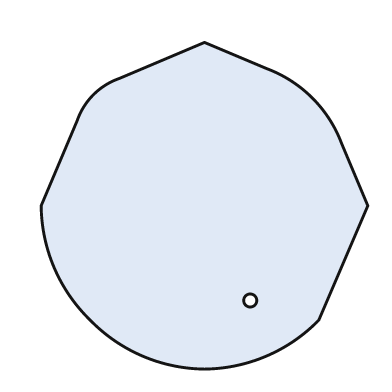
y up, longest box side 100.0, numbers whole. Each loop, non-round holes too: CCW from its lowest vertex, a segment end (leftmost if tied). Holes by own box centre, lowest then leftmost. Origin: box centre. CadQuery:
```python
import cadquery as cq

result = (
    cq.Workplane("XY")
    .moveTo(0.0, -50.0)
    .threePointArc((19.0, -46.0), (35.0, -35.0))
    .lineTo(50.0, 0.0)
    .lineTo(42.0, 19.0)
    .threePointArc((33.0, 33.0), (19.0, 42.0))
    .lineTo(0.0, 50.0)
    .lineTo(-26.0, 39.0)
    .threePointArc((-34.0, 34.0), (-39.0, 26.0))
    .lineTo(-50.0, 0.0)
    .threePointArc((-46.0, -19.0), (-35.0, -35.0))
    .threePointArc((-19.0, -46.0), (0.0, -50.0))
    .close()
    .moveTo(14.0, -29.0)
    .circle(2.0)
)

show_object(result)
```